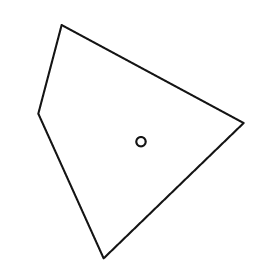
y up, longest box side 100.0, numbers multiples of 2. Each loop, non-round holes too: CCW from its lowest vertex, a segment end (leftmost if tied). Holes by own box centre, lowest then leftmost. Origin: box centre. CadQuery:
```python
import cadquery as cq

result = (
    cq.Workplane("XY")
    .moveTo(-16.0, -50.0)
    .lineTo(44.0, 8.0)
    .lineTo(-34.0, 50.0)
    .lineTo(-44.0, 12.0)
    .close()
    .moveTo(0.0, 0.0)
    .circle(2.0)
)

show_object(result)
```